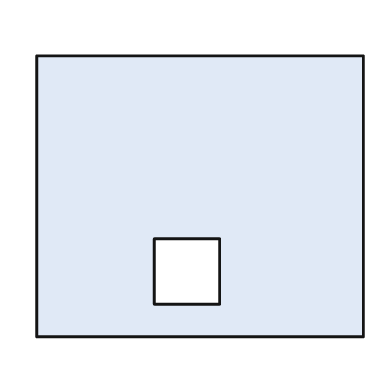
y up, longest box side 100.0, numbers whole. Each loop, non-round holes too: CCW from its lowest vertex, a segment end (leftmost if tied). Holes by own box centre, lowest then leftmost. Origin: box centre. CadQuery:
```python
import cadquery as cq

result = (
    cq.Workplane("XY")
    .moveTo(-50.0, -43.0)
    .lineTo(50.0, -43.0)
    .lineTo(50.0, 43.0)
    .lineTo(-50.0, 43.0)
    .close()
    .moveTo(-14.0, -33.0)
    .lineTo(6.0, -33.0)
    .lineTo(6.0, -13.0)
    .lineTo(-14.0, -13.0)
    .close()
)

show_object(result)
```